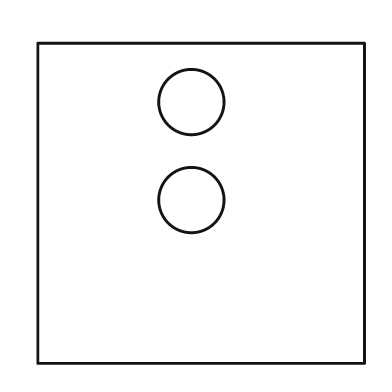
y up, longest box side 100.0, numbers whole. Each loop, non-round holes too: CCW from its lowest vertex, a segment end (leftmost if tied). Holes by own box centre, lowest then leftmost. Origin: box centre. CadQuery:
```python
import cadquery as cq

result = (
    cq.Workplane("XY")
    .moveTo(-50.0, -49.0)
    .lineTo(50.0, -49.0)
    .lineTo(50.0, 49.0)
    .lineTo(-50.0, 49.0)
    .close()
    .moveTo(-3.0, 1.0)
    .circle(10.0)
    .moveTo(-3.0, 31.0)
    .circle(10.0)
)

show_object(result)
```